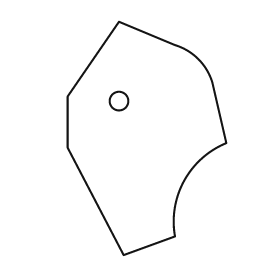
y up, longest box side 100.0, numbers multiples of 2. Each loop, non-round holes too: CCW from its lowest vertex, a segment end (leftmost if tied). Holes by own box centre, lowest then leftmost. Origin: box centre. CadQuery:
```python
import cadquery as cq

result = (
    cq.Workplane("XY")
    .moveTo(-10.0, -50.0)
    .lineTo(12.0, -42.0)
    .threePointArc((16.0, -18.0), (34.0, -2.0))
    .lineTo(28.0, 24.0)
    .threePointArc((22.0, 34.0), (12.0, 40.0))
    .lineTo(-12.0, 50.0)
    .lineTo(-34.0, 18.0)
    .lineTo(-34.0, -4.0)
    .close()
    .moveTo(-12.0, 16.0)
    .circle(4.0)
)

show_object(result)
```